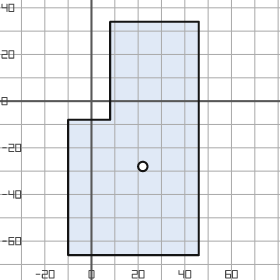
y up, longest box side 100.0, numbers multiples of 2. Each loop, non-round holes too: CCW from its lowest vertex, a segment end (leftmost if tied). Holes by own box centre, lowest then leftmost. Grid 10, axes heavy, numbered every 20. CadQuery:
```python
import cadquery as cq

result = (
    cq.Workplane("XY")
    .moveTo(-10.0, -66.0)
    .lineTo(46.0, -66.0)
    .lineTo(46.0, 34.0)
    .lineTo(8.0, 34.0)
    .lineTo(8.0, -8.0)
    .lineTo(-10.0, -8.0)
    .close()
    .moveTo(22.0, -28.0)
    .circle(2.0)
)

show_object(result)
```